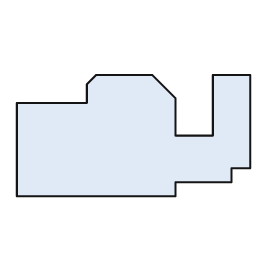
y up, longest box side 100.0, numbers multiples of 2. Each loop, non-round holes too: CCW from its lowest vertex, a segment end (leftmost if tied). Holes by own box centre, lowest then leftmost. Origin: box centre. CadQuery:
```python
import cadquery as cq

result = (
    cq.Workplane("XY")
    .moveTo(-50.0, -26.0)
    .lineTo(18.0, -26.0)
    .lineTo(18.0, -20.0)
    .lineTo(42.0, -20.0)
    .lineTo(42.0, -14.0)
    .lineTo(50.0, -14.0)
    .lineTo(50.0, 26.0)
    .lineTo(34.0, 26.0)
    .lineTo(34.0, 0.0)
    .lineTo(18.0, 0.0)
    .lineTo(18.0, 16.0)
    .lineTo(8.0, 26.0)
    .lineTo(-16.0, 26.0)
    .lineTo(-20.0, 22.0)
    .lineTo(-20.0, 14.0)
    .lineTo(-50.0, 14.0)
    .close()
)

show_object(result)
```